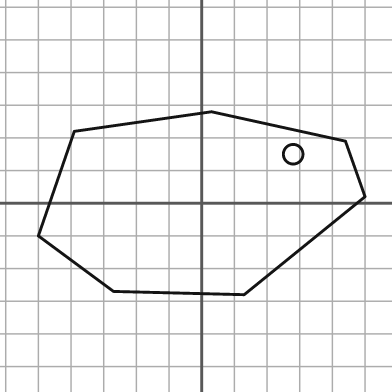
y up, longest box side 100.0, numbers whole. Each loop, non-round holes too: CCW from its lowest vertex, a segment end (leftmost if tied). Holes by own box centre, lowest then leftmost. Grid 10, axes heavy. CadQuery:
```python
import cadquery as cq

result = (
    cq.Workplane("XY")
    .moveTo(13.0, -28.0)
    .lineTo(50.0, 2.0)
    .lineTo(44.0, 19.0)
    .lineTo(3.0, 28.0)
    .lineTo(-39.0, 22.0)
    .lineTo(-50.0, -10.0)
    .lineTo(-27.0, -27.0)
    .close()
    .moveTo(28.0, 15.0)
    .circle(3.0)
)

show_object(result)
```